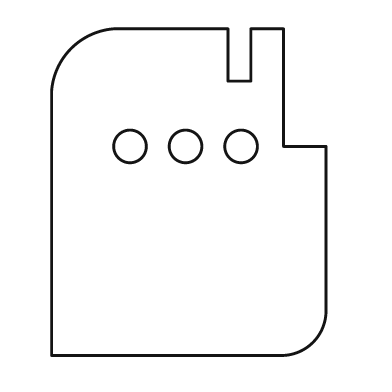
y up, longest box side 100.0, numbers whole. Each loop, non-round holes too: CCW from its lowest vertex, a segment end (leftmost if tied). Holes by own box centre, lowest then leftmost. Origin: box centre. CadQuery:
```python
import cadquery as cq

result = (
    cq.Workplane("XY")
    .moveTo(-42.0, -50.0)
    .lineTo(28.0, -50.0)
    .threePointArc((38.0, -46.0), (42.0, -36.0))
    .lineTo(42.0, 14.0)
    .lineTo(29.0, 14.0)
    .lineTo(29.0, 50.0)
    .lineTo(19.0, 50.0)
    .lineTo(19.0, 34.0)
    .lineTo(12.0, 34.0)
    .lineTo(12.0, 50.0)
    .lineTo(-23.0, 50.0)
    .threePointArc((-36.0, 44.0), (-42.0, 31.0))
    .close()
    .moveTo(-18.0, 14.0)
    .circle(5.0)
    .moveTo(-1.0, 14.0)
    .circle(5.0)
    .moveTo(16.0, 14.0)
    .circle(5.0)
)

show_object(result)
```